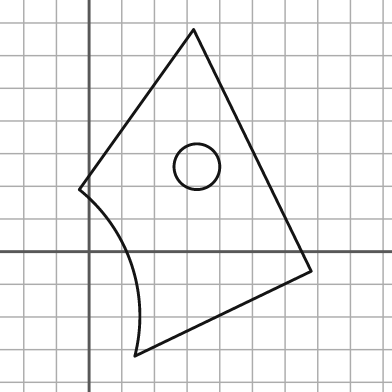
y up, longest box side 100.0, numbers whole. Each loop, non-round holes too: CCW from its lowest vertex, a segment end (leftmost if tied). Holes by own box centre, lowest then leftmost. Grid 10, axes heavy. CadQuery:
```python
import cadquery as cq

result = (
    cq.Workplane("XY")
    .moveTo(14.0, -32.0)
    .lineTo(68.0, -6.0)
    .lineTo(32.0, 68.0)
    .lineTo(-3.0, 19.0)
    .threePointArc((13.0, -4.0), (14.0, -32.0))
    .close()
    .moveTo(33.0, 26.0)
    .circle(7.0)
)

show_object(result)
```